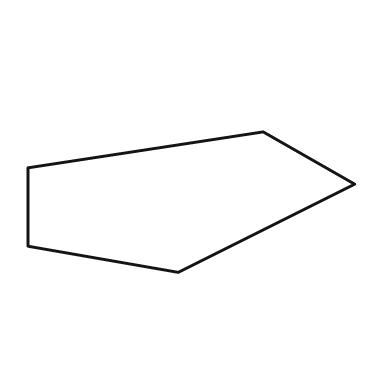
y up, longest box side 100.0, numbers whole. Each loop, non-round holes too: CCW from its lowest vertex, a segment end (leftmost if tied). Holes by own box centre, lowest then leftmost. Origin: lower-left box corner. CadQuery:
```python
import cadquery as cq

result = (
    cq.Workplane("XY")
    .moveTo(46.0, 0.0)
    .lineTo(100.0, 27.0)
    .lineTo(72.0, 43.0)
    .lineTo(0.0, 32.0)
    .lineTo(0.0, 8.0)
    .close()
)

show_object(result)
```